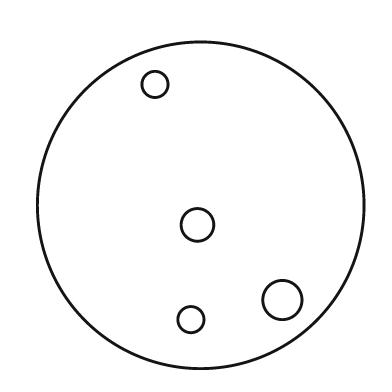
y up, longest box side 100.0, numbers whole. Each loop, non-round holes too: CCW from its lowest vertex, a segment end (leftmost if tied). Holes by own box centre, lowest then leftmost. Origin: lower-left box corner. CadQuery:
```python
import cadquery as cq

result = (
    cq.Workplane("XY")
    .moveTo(50.0, 50.0)
    .circle(50.0)
    .moveTo(47.0, 15.0)
    .circle(4.0)
    .moveTo(75.0, 21.0)
    .circle(6.0)
    .moveTo(49.0, 44.0)
    .circle(5.0)
    .moveTo(36.0, 87.0)
    .circle(4.0)
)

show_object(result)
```